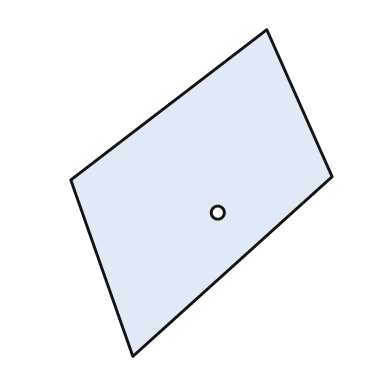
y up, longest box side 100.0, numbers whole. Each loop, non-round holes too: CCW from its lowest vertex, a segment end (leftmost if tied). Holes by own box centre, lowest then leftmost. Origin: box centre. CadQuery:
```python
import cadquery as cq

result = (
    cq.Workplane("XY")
    .moveTo(-21.0, -50.0)
    .lineTo(40.0, 5.0)
    .lineTo(20.0, 50.0)
    .lineTo(-40.0, 4.0)
    .close()
    .moveTo(5.0, -6.0)
    .circle(2.0)
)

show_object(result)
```